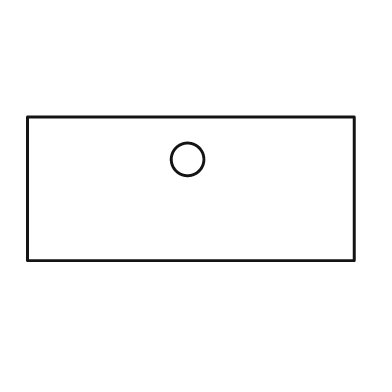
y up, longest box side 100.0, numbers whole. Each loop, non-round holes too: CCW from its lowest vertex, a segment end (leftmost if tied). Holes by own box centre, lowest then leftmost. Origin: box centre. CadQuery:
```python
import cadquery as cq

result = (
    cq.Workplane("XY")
    .moveTo(-50.0, -22.0)
    .lineTo(50.0, -22.0)
    .lineTo(50.0, 22.0)
    .lineTo(-50.0, 22.0)
    .close()
    .moveTo(-1.0, 9.0)
    .circle(5.0)
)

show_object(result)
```